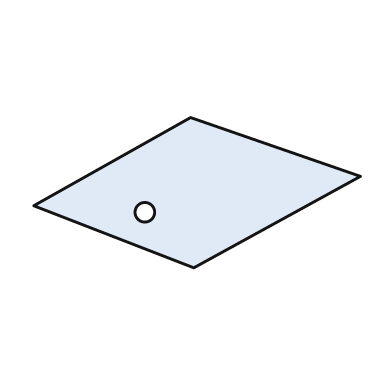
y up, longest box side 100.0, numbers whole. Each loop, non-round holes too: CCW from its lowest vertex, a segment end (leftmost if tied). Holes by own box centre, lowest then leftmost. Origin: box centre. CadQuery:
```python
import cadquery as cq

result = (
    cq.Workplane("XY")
    .moveTo(-1.0, -23.0)
    .lineTo(50.0, 5.0)
    .lineTo(-2.0, 23.0)
    .lineTo(-50.0, -4.0)
    .close()
    .moveTo(-16.0, -6.0)
    .circle(3.0)
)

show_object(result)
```